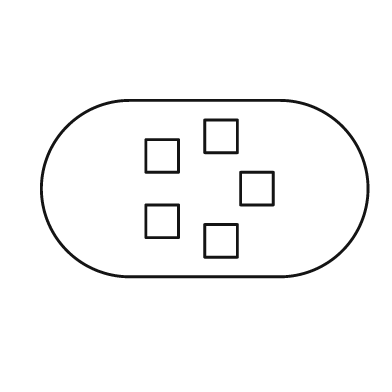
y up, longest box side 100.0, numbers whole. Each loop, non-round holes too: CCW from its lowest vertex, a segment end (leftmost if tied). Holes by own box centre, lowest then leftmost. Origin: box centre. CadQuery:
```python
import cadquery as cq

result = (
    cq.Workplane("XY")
    .moveTo(-23.0, -27.0)
    .lineTo(23.0, -27.0)
    .threePointArc((50.0, 0.0), (23.0, 27.0))
    .lineTo(-23.0, 27.0)
    .threePointArc((-50.0, 0.0), (-23.0, -27.0))
    .close()
    .moveTo(0.0, -21.0)
    .lineTo(10.0, -21.0)
    .lineTo(10.0, -11.0)
    .lineTo(0.0, -11.0)
    .close()
    .moveTo(-18.0, -15.0)
    .lineTo(-8.0, -15.0)
    .lineTo(-8.0, -5.0)
    .lineTo(-18.0, -5.0)
    .close()
    .moveTo(11.0, -5.0)
    .lineTo(21.0, -5.0)
    .lineTo(21.0, 5.0)
    .lineTo(11.0, 5.0)
    .close()
    .moveTo(-18.0, 5.0)
    .lineTo(-8.0, 5.0)
    .lineTo(-8.0, 15.0)
    .lineTo(-18.0, 15.0)
    .close()
    .moveTo(0.0, 11.0)
    .lineTo(10.0, 11.0)
    .lineTo(10.0, 21.0)
    .lineTo(0.0, 21.0)
    .close()
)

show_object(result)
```